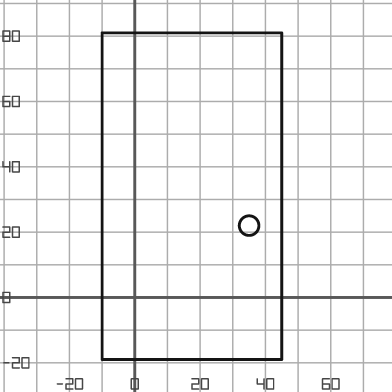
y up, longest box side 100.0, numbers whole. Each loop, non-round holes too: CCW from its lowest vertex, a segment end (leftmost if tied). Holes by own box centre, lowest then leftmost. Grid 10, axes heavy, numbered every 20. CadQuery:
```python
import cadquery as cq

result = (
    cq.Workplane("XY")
    .moveTo(-10.0, -19.0)
    .lineTo(45.0, -19.0)
    .lineTo(45.0, 81.0)
    .lineTo(-10.0, 81.0)
    .close()
    .moveTo(35.0, 22.0)
    .circle(3.0)
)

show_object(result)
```